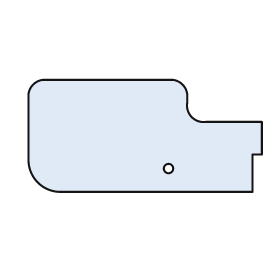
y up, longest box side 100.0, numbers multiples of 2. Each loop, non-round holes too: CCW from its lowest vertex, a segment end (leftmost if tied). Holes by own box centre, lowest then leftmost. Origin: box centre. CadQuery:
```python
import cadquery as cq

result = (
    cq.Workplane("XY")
    .moveTo(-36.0, -24.0)
    .lineTo(46.0, -24.0)
    .lineTo(46.0, -8.0)
    .lineTo(50.0, -8.0)
    .lineTo(50.0, 6.0)
    .lineTo(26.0, 6.0)
    .threePointArc((20.0, 8.0), (18.0, 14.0))
    .lineTo(18.0, 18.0)
    .threePointArc((16.0, 22.0), (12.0, 24.0))
    .lineTo(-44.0, 24.0)
    .threePointArc((-48.0, 22.0), (-50.0, 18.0))
    .lineTo(-50.0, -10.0)
    .threePointArc((-46.0, -20.0), (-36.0, -24.0))
    .close()
    .moveTo(10.0, -14.0)
    .circle(2.0)
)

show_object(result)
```